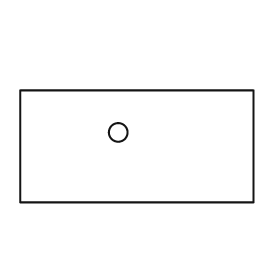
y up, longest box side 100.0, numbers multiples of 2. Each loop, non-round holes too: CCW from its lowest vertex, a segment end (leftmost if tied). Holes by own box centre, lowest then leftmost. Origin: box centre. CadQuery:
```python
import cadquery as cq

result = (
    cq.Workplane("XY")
    .moveTo(-50.0, -24.0)
    .lineTo(50.0, -24.0)
    .lineTo(50.0, 24.0)
    .lineTo(-50.0, 24.0)
    .close()
    .moveTo(-8.0, 6.0)
    .circle(4.0)
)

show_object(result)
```